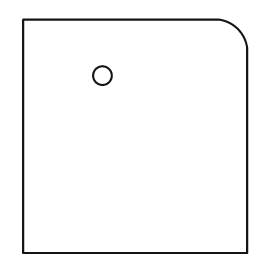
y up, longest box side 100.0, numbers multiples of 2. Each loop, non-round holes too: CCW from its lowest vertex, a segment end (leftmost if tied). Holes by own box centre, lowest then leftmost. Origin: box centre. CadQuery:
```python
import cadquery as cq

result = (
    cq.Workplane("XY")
    .moveTo(-48.0, -50.0)
    .lineTo(48.0, -50.0)
    .lineTo(48.0, 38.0)
    .threePointArc((44.0, 46.0), (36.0, 50.0))
    .lineTo(-48.0, 50.0)
    .close()
    .moveTo(-14.0, 26.0)
    .circle(4.0)
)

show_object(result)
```